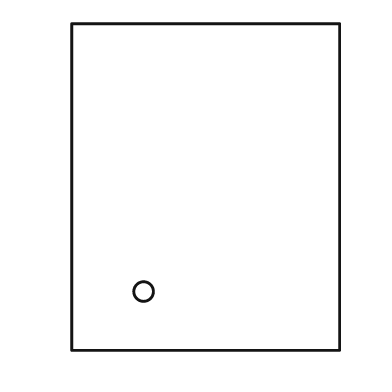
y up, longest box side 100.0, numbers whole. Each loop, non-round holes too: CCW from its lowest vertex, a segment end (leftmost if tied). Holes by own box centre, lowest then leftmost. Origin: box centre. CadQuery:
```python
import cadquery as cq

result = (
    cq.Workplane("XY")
    .moveTo(-41.0, -50.0)
    .lineTo(41.0, -50.0)
    .lineTo(41.0, 50.0)
    .lineTo(-41.0, 50.0)
    .close()
    .moveTo(-19.0, -32.0)
    .circle(3.0)
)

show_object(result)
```